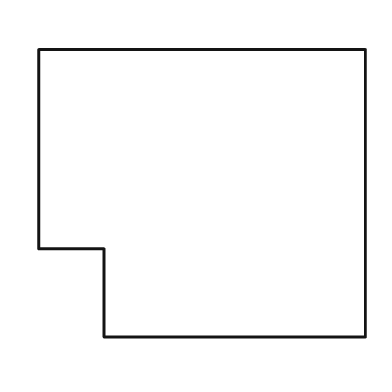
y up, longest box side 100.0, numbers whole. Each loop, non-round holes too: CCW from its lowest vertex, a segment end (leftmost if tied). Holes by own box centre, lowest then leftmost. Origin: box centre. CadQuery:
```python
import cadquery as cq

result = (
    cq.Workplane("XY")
    .moveTo(-30.0, -44.0)
    .lineTo(50.0, -44.0)
    .lineTo(50.0, 44.0)
    .lineTo(-50.0, 44.0)
    .lineTo(-50.0, -17.0)
    .lineTo(-30.0, -17.0)
    .close()
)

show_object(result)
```